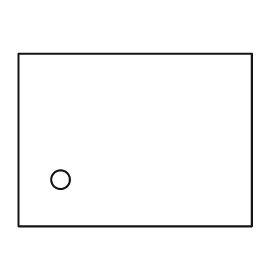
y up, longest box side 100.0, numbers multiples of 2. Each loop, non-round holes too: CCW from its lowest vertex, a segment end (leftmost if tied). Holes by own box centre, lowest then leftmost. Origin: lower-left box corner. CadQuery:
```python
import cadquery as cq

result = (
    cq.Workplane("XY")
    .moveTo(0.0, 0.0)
    .lineTo(100.0, 0.0)
    .lineTo(100.0, 74.0)
    .lineTo(0.0, 74.0)
    .close()
    .moveTo(18.0, 20.0)
    .circle(4.0)
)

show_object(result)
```